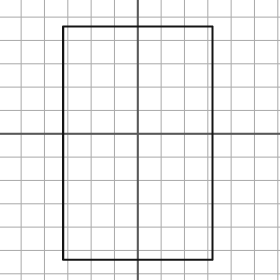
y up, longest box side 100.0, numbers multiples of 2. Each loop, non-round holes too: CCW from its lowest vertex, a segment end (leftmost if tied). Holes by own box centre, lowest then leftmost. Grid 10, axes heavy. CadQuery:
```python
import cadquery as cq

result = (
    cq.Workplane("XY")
    .moveTo(-32.0, -54.0)
    .lineTo(32.0, -54.0)
    .lineTo(32.0, 46.0)
    .lineTo(-32.0, 46.0)
    .close()
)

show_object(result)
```